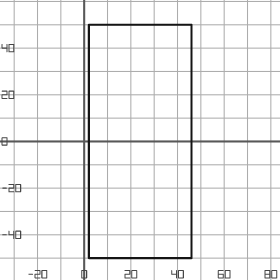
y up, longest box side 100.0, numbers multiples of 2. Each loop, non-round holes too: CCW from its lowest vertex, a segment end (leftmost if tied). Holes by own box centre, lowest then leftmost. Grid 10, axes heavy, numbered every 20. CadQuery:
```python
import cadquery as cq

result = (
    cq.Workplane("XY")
    .moveTo(2.0, -50.0)
    .lineTo(46.0, -50.0)
    .lineTo(46.0, 50.0)
    .lineTo(2.0, 50.0)
    .close()
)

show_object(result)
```